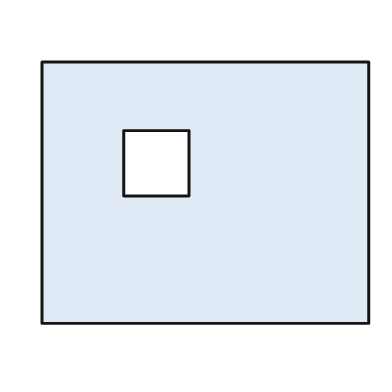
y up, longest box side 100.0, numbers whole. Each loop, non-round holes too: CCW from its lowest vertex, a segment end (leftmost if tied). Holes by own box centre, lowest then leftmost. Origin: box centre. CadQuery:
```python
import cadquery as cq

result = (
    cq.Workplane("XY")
    .moveTo(-50.0, -40.0)
    .lineTo(50.0, -40.0)
    .lineTo(50.0, 40.0)
    .lineTo(-50.0, 40.0)
    .close()
    .moveTo(-25.0, -1.0)
    .lineTo(-5.0, -1.0)
    .lineTo(-5.0, 19.0)
    .lineTo(-25.0, 19.0)
    .close()
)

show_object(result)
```